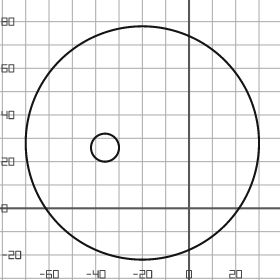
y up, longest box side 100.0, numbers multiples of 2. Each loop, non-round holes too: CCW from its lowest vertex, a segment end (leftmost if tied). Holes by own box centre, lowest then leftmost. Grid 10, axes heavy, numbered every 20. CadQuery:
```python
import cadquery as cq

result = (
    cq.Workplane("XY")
    .moveTo(-20.0, 28.0)
    .circle(50.0)
    .moveTo(-36.0, 26.0)
    .circle(6.0)
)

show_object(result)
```